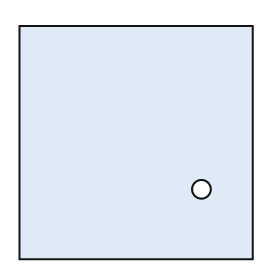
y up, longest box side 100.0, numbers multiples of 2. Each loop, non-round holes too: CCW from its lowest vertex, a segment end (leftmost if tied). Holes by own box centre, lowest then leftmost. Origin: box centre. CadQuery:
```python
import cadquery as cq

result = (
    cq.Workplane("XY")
    .moveTo(-50.0, -50.0)
    .lineTo(50.0, -50.0)
    .lineTo(50.0, 50.0)
    .lineTo(-50.0, 50.0)
    .close()
    .moveTo(28.0, -20.0)
    .circle(4.0)
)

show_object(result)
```